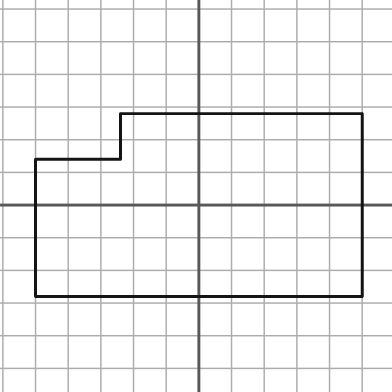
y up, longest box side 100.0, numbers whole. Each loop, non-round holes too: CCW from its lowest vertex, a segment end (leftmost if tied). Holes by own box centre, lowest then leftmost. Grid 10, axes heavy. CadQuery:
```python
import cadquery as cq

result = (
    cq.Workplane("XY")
    .moveTo(-50.0, -28.0)
    .lineTo(50.0, -28.0)
    .lineTo(50.0, 28.0)
    .lineTo(-24.0, 28.0)
    .lineTo(-24.0, 14.0)
    .lineTo(-50.0, 14.0)
    .close()
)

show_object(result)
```